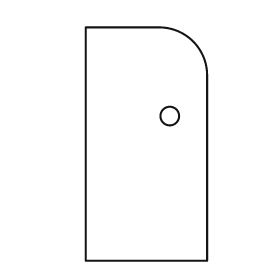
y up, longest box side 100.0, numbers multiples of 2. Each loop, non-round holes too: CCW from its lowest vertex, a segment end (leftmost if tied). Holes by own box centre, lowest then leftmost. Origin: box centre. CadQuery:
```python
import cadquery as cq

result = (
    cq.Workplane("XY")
    .moveTo(-26.0, -50.0)
    .lineTo(26.0, -50.0)
    .lineTo(26.0, 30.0)
    .threePointArc((20.0, 44.0), (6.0, 50.0))
    .lineTo(-26.0, 50.0)
    .close()
    .moveTo(10.0, 12.0)
    .circle(4.0)
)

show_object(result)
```